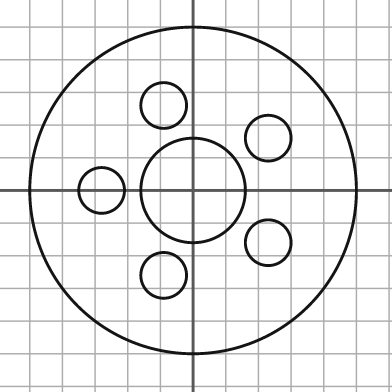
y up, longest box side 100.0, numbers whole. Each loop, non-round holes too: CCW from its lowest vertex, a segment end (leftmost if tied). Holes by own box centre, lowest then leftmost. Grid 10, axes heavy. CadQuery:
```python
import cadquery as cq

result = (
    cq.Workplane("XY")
    .moveTo(0.0, 0.0)
    .circle(50.0)
    .moveTo(-9.0, -26.0)
    .circle(7.0)
    .moveTo(23.0, -16.0)
    .circle(7.0)
    .moveTo(-28.0, 0.0)
    .circle(7.0)
    .moveTo(0.0, 0.0)
    .circle(16.0)
    .moveTo(23.0, 16.0)
    .circle(7.0)
    .moveTo(-9.0, 26.0)
    .circle(7.0)
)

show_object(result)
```